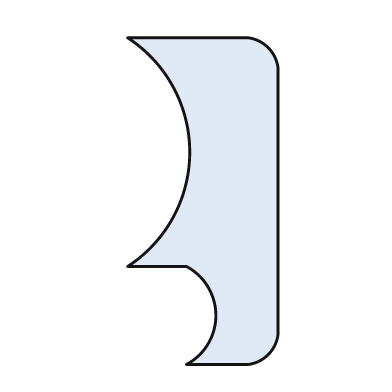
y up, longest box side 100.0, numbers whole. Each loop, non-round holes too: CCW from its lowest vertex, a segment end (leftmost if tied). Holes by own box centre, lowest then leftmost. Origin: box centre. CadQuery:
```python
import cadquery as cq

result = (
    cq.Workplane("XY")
    .moveTo(-5.0, -50.0)
    .lineTo(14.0, -50.0)
    .threePointArc((20.0, -47.0), (23.0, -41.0))
    .lineTo(23.0, 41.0)
    .threePointArc((20.0, 47.0), (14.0, 50.0))
    .lineTo(-23.0, 50.0)
    .threePointArc((-4.0, 15.0), (-23.0, -20.0))
    .lineTo(-5.0, -20.0)
    .threePointArc((4.0, -35.0), (-5.0, -50.0))
    .close()
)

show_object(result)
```